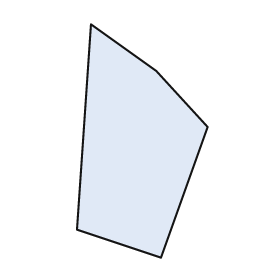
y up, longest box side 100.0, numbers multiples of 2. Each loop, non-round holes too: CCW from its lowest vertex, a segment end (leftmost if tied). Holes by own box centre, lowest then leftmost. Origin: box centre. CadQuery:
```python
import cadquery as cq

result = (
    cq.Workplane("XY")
    .moveTo(8.0, -50.0)
    .lineTo(28.0, 6.0)
    .lineTo(6.0, 30.0)
    .lineTo(-22.0, 50.0)
    .lineTo(-28.0, -38.0)
    .close()
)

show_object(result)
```